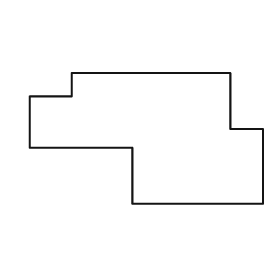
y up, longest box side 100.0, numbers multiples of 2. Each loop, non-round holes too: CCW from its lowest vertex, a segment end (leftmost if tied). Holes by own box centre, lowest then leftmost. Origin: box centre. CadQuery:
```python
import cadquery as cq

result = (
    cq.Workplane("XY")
    .moveTo(-6.0, -28.0)
    .lineTo(50.0, -28.0)
    .lineTo(50.0, 4.0)
    .lineTo(36.0, 4.0)
    .lineTo(36.0, 28.0)
    .lineTo(-32.0, 28.0)
    .lineTo(-32.0, 18.0)
    .lineTo(-50.0, 18.0)
    .lineTo(-50.0, -4.0)
    .lineTo(-6.0, -4.0)
    .close()
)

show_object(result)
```